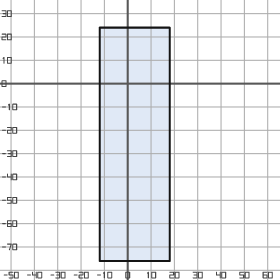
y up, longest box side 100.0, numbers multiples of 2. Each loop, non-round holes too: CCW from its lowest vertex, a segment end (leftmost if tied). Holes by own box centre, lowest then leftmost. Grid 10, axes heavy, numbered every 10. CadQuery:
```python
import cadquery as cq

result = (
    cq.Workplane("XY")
    .moveTo(-12.0, -76.0)
    .lineTo(18.0, -76.0)
    .lineTo(18.0, 24.0)
    .lineTo(-12.0, 24.0)
    .close()
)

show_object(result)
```